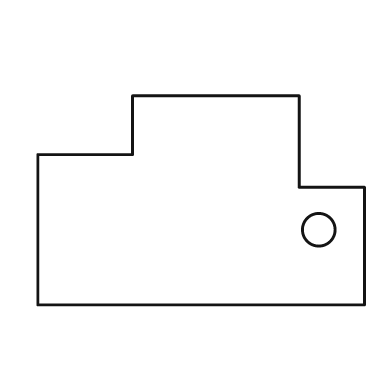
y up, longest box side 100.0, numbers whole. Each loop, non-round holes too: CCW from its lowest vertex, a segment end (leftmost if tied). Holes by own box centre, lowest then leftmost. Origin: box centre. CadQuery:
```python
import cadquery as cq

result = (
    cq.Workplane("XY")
    .moveTo(-50.0, -32.0)
    .lineTo(50.0, -32.0)
    .lineTo(50.0, 4.0)
    .lineTo(30.0, 4.0)
    .lineTo(30.0, 32.0)
    .lineTo(-21.0, 32.0)
    .lineTo(-21.0, 14.0)
    .lineTo(-50.0, 14.0)
    .close()
    .moveTo(36.0, -9.0)
    .circle(5.0)
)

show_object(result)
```